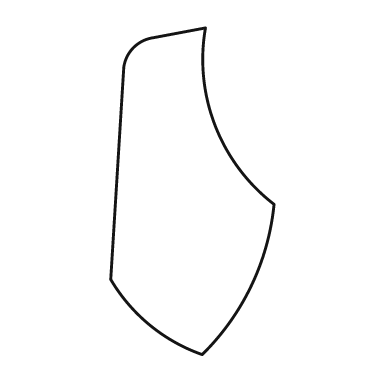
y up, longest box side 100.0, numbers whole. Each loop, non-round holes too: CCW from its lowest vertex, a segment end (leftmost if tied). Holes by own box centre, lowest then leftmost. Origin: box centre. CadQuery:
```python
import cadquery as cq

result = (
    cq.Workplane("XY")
    .moveTo(3.0, -50.0)
    .threePointArc((18.0, -29.0), (25.0, -4.0))
    .threePointArc((7.0, 20.0), (4.0, 50.0))
    .lineTo(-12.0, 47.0)
    .threePointArc((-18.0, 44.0), (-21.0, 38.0))
    .lineTo(-25.0, -27.0)
    .threePointArc((-13.0, -41.0), (3.0, -50.0))
    .close()
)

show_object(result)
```